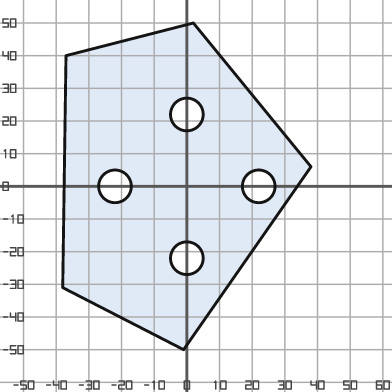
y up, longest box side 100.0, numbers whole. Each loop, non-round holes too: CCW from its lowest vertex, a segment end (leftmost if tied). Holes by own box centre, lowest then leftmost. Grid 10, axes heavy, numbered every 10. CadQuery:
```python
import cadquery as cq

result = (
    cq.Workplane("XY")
    .moveTo(-1.0, -50.0)
    .lineTo(38.0, 6.0)
    .lineTo(2.0, 50.0)
    .lineTo(-37.0, 40.0)
    .lineTo(-38.0, -31.0)
    .close()
    .moveTo(0.0, -22.0)
    .circle(5.0)
    .moveTo(-22.0, 0.0)
    .circle(5.0)
    .moveTo(22.0, 0.0)
    .circle(5.0)
    .moveTo(0.0, 22.0)
    .circle(5.0)
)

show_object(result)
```